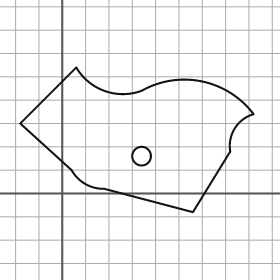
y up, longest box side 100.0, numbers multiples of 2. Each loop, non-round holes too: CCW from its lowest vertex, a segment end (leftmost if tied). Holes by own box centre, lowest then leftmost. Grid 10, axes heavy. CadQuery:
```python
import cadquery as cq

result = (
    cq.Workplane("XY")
    .moveTo(56.0, -8.0)
    .lineTo(72.0, 18.0)
    .threePointArc((74.0, 28.0), (82.0, 34.0))
    .threePointArc((60.0, 48.0), (34.0, 44.0))
    .threePointArc((18.0, 44.0), (6.0, 54.0))
    .lineTo(-18.0, 30.0)
    .lineTo(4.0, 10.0)
    .threePointArc((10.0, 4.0), (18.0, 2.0))
    .close()
    .moveTo(34.0, 16.0)
    .circle(4.0)
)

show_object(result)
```